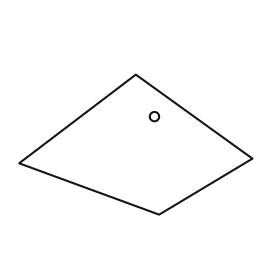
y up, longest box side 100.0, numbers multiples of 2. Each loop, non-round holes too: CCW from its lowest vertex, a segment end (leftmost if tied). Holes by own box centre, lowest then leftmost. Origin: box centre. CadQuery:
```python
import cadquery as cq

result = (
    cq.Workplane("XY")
    .moveTo(10.0, -30.0)
    .lineTo(50.0, -6.0)
    .lineTo(0.0, 30.0)
    .lineTo(-50.0, -8.0)
    .close()
    .moveTo(8.0, 12.0)
    .circle(2.0)
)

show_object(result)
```